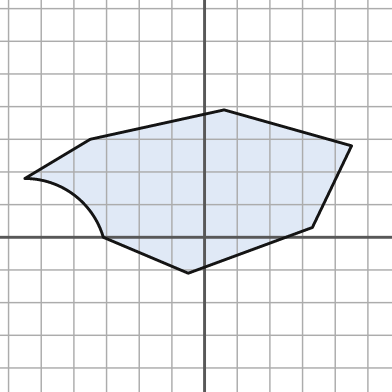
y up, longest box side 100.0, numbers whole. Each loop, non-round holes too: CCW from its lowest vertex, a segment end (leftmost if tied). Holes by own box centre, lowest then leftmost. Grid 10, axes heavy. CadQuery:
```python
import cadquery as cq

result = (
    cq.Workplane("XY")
    .moveTo(-5.0, -11.0)
    .lineTo(33.0, 3.0)
    .lineTo(45.0, 28.0)
    .lineTo(6.0, 39.0)
    .lineTo(-35.0, 30.0)
    .lineTo(-55.0, 18.0)
    .threePointArc((-40.0, 13.0), (-31.0, 0.0))
    .close()
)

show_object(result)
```